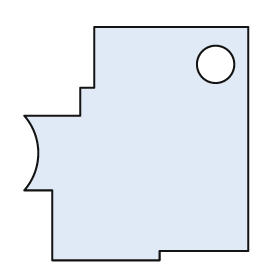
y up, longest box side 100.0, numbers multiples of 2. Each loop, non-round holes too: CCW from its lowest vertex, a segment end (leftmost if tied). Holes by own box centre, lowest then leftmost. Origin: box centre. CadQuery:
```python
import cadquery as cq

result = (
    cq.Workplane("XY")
    .moveTo(-36.0, -50.0)
    .lineTo(10.0, -50.0)
    .lineTo(10.0, -46.0)
    .lineTo(48.0, -46.0)
    .lineTo(48.0, 50.0)
    .lineTo(-18.0, 50.0)
    .lineTo(-18.0, 24.0)
    .lineTo(-24.0, 24.0)
    .lineTo(-24.0, 12.0)
    .lineTo(-48.0, 12.0)
    .threePointArc((-42.0, -4.0), (-48.0, -20.0))
    .lineTo(-36.0, -20.0)
    .close()
    .moveTo(34.0, 34.0)
    .circle(8.0)
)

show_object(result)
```